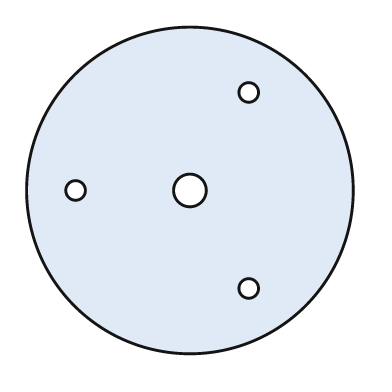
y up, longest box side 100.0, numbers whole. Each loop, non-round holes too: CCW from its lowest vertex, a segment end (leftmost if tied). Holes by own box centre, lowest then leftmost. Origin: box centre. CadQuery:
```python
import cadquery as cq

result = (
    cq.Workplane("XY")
    .moveTo(0.0, 0.0)
    .circle(50.0)
    .moveTo(18.0, -30.0)
    .circle(3.0)
    .moveTo(-35.0, 0.0)
    .circle(3.0)
    .moveTo(0.0, 0.0)
    .circle(5.0)
    .moveTo(18.0, 30.0)
    .circle(3.0)
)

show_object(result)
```